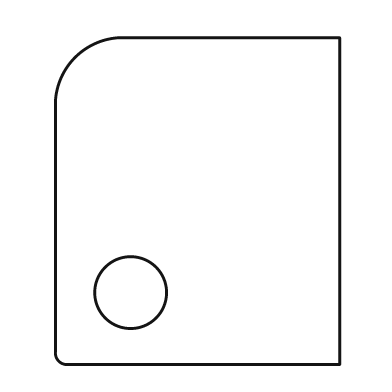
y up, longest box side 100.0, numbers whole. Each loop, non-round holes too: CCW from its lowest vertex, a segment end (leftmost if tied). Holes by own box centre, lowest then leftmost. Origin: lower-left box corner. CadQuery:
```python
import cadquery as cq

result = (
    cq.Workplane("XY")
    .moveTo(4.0, 0.0)
    .lineTo(87.0, 0.0)
    .lineTo(87.0, 100.0)
    .lineTo(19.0, 100.0)
    .threePointArc((6.0, 94.0), (0.0, 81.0))
    .lineTo(0.0, 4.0)
    .threePointArc((1.0, 1.0), (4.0, 0.0))
    .close()
    .moveTo(23.0, 22.0)
    .circle(11.0)
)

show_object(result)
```